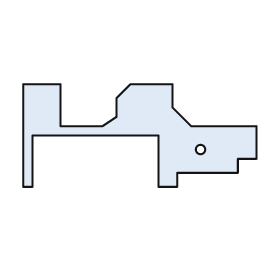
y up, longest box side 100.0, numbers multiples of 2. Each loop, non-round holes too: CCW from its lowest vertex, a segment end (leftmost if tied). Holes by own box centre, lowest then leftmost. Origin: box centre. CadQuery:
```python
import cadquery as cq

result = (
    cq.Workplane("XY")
    .moveTo(-50.0, -22.0)
    .lineTo(-46.0, -22.0)
    .lineTo(-46.0, 0.0)
    .lineTo(8.0, 0.0)
    .lineTo(8.0, -22.0)
    .lineTo(16.0, -22.0)
    .lineTo(16.0, -16.0)
    .lineTo(42.0, -16.0)
    .lineTo(42.0, -10.0)
    .lineTo(50.0, -10.0)
    .lineTo(50.0, 4.0)
    .lineTo(22.0, 4.0)
    .lineTo(14.0, 12.0)
    .lineTo(14.0, 22.0)
    .lineTo(-4.0, 22.0)
    .lineTo(-10.0, 16.0)
    .lineTo(-10.0, 8.0)
    .lineTo(-16.0, 4.0)
    .lineTo(-34.0, 4.0)
    .lineTo(-34.0, 22.0)
    .lineTo(-50.0, 22.0)
    .close()
    .moveTo(26.0, -6.0)
    .circle(2.0)
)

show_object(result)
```